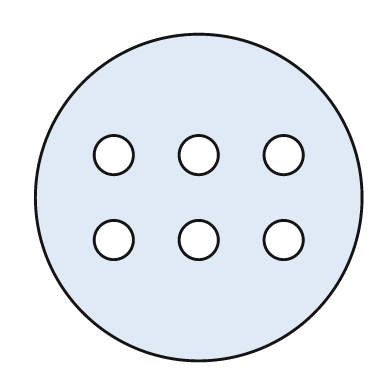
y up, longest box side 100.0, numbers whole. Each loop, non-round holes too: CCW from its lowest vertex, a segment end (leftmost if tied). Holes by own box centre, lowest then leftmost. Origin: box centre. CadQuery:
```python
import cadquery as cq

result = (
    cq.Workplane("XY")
    .moveTo(0.0, 0.0)
    .circle(50.0)
    .moveTo(-26.0, -13.0)
    .circle(6.0)
    .moveTo(0.0, -13.0)
    .circle(6.0)
    .moveTo(26.0, -13.0)
    .circle(6.0)
    .moveTo(-26.0, 13.0)
    .circle(6.0)
    .moveTo(0.0, 13.0)
    .circle(6.0)
    .moveTo(26.0, 13.0)
    .circle(6.0)
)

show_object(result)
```